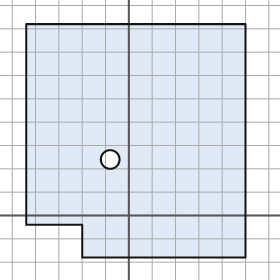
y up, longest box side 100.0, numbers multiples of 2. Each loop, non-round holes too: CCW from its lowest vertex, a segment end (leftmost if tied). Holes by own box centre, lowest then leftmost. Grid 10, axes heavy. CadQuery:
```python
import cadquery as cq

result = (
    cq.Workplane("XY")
    .moveTo(-20.0, -18.0)
    .lineTo(50.0, -18.0)
    .lineTo(50.0, 82.0)
    .lineTo(-44.0, 82.0)
    .lineTo(-44.0, -4.0)
    .lineTo(-20.0, -4.0)
    .close()
    .moveTo(-8.0, 24.0)
    .circle(4.0)
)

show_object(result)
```